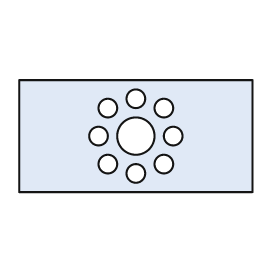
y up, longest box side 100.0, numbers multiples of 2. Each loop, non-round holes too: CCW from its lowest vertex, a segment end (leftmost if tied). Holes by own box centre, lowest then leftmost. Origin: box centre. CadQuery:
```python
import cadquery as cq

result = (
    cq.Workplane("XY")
    .moveTo(-50.0, -24.0)
    .lineTo(50.0, -24.0)
    .lineTo(50.0, 24.0)
    .lineTo(-50.0, 24.0)
    .close()
    .moveTo(0.0, -16.0)
    .circle(4.0)
    .moveTo(-12.0, -12.0)
    .circle(4.0)
    .moveTo(12.0, -12.0)
    .circle(4.0)
    .moveTo(-16.0, 0.0)
    .circle(4.0)
    .moveTo(0.0, 0.0)
    .circle(8.0)
    .moveTo(16.0, 0.0)
    .circle(4.0)
    .moveTo(-12.0, 12.0)
    .circle(4.0)
    .moveTo(12.0, 12.0)
    .circle(4.0)
    .moveTo(0.0, 16.0)
    .circle(4.0)
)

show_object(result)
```